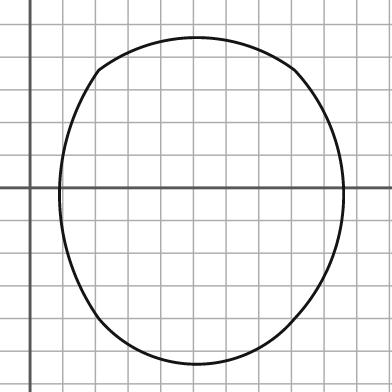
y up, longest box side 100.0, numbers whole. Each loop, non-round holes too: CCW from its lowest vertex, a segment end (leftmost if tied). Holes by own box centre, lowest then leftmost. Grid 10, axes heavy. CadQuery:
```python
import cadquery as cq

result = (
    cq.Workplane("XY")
    .moveTo(21.0, -40.0)
    .threePointArc((51.0, -54.0), (81.0, -40.0))
    .threePointArc((96.0, -2.0), (81.0, 36.0))
    .threePointArc((51.0, 46.0), (21.0, 36.0))
    .threePointArc((9.0, -2.0), (21.0, -40.0))
    .close()
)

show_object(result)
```